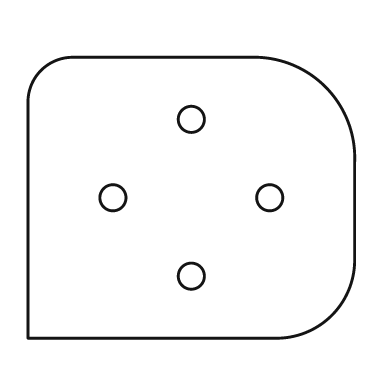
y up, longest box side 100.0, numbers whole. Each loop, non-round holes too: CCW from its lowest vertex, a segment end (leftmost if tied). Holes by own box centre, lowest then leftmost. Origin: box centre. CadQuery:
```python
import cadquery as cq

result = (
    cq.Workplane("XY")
    .moveTo(-50.0, -43.0)
    .lineTo(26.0, -43.0)
    .threePointArc((43.0, -36.0), (50.0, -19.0))
    .lineTo(50.0, 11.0)
    .threePointArc((41.0, 34.0), (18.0, 43.0))
    .lineTo(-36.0, 43.0)
    .threePointArc((-46.0, 39.0), (-50.0, 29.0))
    .close()
    .moveTo(0.0, -24.0)
    .circle(4.0)
    .moveTo(-24.0, 0.0)
    .circle(4.0)
    .moveTo(24.0, 0.0)
    .circle(4.0)
    .moveTo(0.0, 24.0)
    .circle(4.0)
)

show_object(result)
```